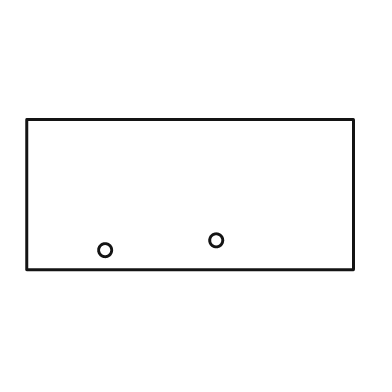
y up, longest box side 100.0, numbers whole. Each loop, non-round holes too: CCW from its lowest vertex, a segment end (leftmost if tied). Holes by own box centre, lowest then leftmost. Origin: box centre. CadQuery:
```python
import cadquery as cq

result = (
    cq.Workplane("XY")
    .moveTo(-50.0, -23.0)
    .lineTo(50.0, -23.0)
    .lineTo(50.0, 23.0)
    .lineTo(-50.0, 23.0)
    .close()
    .moveTo(-26.0, -17.0)
    .circle(2.0)
    .moveTo(8.0, -14.0)
    .circle(2.0)
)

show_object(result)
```